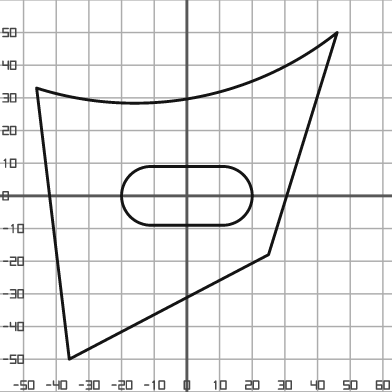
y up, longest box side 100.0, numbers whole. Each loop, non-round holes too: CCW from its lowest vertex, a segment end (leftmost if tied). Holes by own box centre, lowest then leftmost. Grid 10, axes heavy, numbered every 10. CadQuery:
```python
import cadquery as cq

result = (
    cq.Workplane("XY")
    .moveTo(-36.0, -50.0)
    .lineTo(25.0, -18.0)
    .lineTo(46.0, 50.0)
    .threePointArc((2.0, 30.0), (-46.0, 33.0))
    .close()
    .moveTo(-11.0, -9.0)
    .lineTo(11.0, -9.0)
    .threePointArc((20.0, 0.0), (11.0, 9.0))
    .lineTo(-11.0, 9.0)
    .threePointArc((-20.0, 0.0), (-11.0, -9.0))
    .close()
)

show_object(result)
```